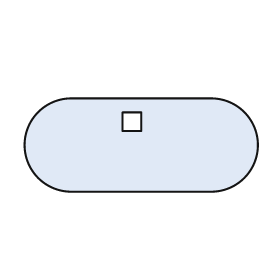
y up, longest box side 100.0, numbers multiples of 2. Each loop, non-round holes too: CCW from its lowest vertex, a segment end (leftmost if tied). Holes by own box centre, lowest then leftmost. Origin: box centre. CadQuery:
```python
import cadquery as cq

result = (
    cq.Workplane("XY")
    .moveTo(-30.0, -20.0)
    .lineTo(30.0, -20.0)
    .threePointArc((50.0, 0.0), (30.0, 20.0))
    .lineTo(-30.0, 20.0)
    .threePointArc((-50.0, 0.0), (-30.0, -20.0))
    .close()
    .moveTo(-8.0, 6.0)
    .lineTo(0.0, 6.0)
    .lineTo(0.0, 14.0)
    .lineTo(-8.0, 14.0)
    .close()
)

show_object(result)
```